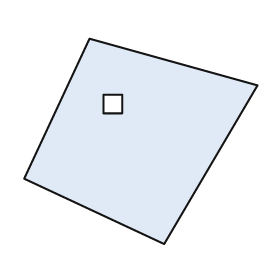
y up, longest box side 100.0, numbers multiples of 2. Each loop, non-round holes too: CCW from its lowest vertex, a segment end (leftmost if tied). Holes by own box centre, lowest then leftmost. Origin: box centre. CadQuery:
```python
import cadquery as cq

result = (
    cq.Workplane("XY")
    .moveTo(10.0, -44.0)
    .lineTo(50.0, 24.0)
    .lineTo(-22.0, 44.0)
    .lineTo(-50.0, -16.0)
    .close()
    .moveTo(-16.0, 12.0)
    .lineTo(-8.0, 12.0)
    .lineTo(-8.0, 20.0)
    .lineTo(-16.0, 20.0)
    .close()
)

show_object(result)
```